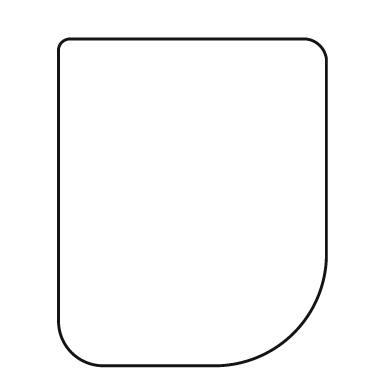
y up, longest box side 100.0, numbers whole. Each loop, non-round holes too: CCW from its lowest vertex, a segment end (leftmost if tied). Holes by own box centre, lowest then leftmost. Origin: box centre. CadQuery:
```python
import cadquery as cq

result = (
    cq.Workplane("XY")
    .moveTo(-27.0, -50.0)
    .lineTo(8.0, -50.0)
    .threePointArc((31.0, -40.0), (41.0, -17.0))
    .lineTo(41.0, 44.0)
    .threePointArc((39.0, 48.0), (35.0, 50.0))
    .lineTo(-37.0, 50.0)
    .threePointArc((-40.0, 49.0), (-41.0, 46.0))
    .lineTo(-41.0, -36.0)
    .threePointArc((-37.0, -46.0), (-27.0, -50.0))
    .close()
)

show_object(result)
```